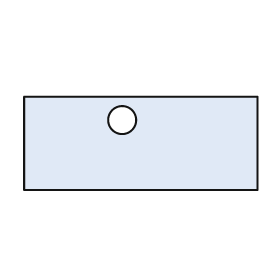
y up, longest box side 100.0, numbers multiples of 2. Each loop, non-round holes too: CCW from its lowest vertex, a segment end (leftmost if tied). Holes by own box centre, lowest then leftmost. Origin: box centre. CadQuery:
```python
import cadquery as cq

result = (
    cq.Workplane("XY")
    .moveTo(-50.0, -20.0)
    .lineTo(50.0, -20.0)
    .lineTo(50.0, 20.0)
    .lineTo(-50.0, 20.0)
    .close()
    .moveTo(-8.0, 10.0)
    .circle(6.0)
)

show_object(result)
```